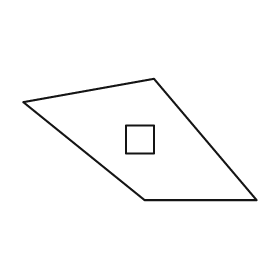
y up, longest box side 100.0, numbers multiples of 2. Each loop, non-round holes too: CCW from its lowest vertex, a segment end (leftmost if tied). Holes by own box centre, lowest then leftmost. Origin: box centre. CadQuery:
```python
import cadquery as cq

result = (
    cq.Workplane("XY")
    .moveTo(2.0, -26.0)
    .lineTo(50.0, -26.0)
    .lineTo(6.0, 26.0)
    .lineTo(-50.0, 16.0)
    .close()
    .moveTo(-6.0, -6.0)
    .lineTo(6.0, -6.0)
    .lineTo(6.0, 6.0)
    .lineTo(-6.0, 6.0)
    .close()
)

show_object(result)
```